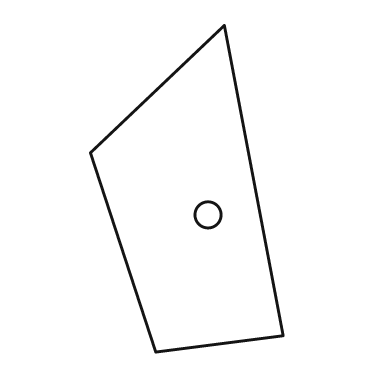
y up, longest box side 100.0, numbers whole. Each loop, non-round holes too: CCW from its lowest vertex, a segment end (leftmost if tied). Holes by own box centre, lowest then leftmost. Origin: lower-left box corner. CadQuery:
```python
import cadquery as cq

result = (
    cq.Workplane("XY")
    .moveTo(20.0, 0.0)
    .lineTo(59.0, 5.0)
    .lineTo(41.0, 100.0)
    .lineTo(0.0, 61.0)
    .close()
    .moveTo(36.0, 42.0)
    .circle(4.0)
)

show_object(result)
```